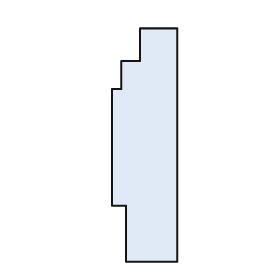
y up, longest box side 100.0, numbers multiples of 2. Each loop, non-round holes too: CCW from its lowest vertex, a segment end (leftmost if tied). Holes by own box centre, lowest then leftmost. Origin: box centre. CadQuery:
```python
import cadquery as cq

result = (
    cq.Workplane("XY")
    .moveTo(-8.0, -50.0)
    .lineTo(14.0, -50.0)
    .lineTo(14.0, 50.0)
    .lineTo(-2.0, 50.0)
    .lineTo(-2.0, 36.0)
    .lineTo(-10.0, 36.0)
    .lineTo(-10.0, 24.0)
    .lineTo(-14.0, 24.0)
    .lineTo(-14.0, -26.0)
    .lineTo(-8.0, -26.0)
    .close()
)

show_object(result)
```